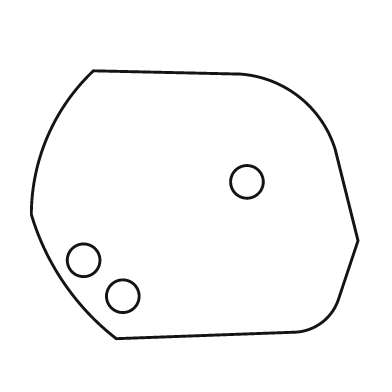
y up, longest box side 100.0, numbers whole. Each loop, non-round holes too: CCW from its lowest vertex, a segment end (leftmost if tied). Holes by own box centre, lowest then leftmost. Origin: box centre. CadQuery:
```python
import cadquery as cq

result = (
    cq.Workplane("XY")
    .moveTo(-24.0, -41.0)
    .lineTo(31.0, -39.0)
    .threePointArc((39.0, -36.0), (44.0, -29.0))
    .lineTo(50.0, -11.0)
    .lineTo(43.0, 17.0)
    .threePointArc((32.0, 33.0), (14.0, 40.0))
    .lineTo(-31.0, 41.0)
    .threePointArc((-45.0, 21.0), (-50.0, -3.0))
    .threePointArc((-40.0, -24.0), (-24.0, -41.0))
    .close()
    .moveTo(-22.0, -28.0)
    .circle(5.0)
    .moveTo(-34.0, -17.0)
    .circle(5.0)
    .moveTo(16.0, 7.0)
    .circle(5.0)
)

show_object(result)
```